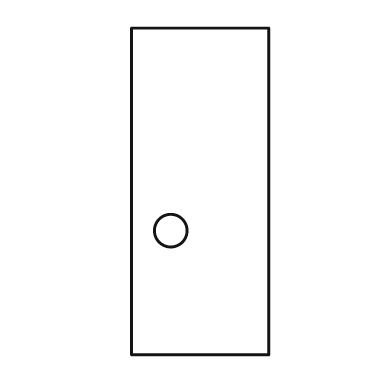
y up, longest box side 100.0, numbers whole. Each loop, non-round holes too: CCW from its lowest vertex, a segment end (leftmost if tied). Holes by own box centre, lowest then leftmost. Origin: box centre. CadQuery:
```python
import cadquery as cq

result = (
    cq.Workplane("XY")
    .moveTo(-21.0, -50.0)
    .lineTo(21.0, -50.0)
    .lineTo(21.0, 50.0)
    .lineTo(-21.0, 50.0)
    .close()
    .moveTo(-9.0, -12.0)
    .circle(5.0)
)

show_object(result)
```